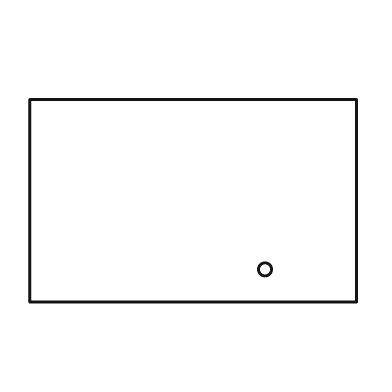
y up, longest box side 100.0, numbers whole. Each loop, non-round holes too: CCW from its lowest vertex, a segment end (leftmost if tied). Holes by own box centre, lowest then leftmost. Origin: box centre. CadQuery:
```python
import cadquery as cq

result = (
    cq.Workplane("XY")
    .moveTo(-50.0, -31.0)
    .lineTo(50.0, -31.0)
    .lineTo(50.0, 31.0)
    .lineTo(-50.0, 31.0)
    .close()
    .moveTo(22.0, -21.0)
    .circle(2.0)
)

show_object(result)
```